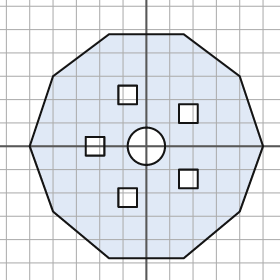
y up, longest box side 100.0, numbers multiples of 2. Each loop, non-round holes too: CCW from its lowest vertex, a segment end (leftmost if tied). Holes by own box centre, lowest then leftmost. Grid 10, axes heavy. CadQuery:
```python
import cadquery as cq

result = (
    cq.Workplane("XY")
    .moveTo(-16.0, -48.0)
    .lineTo(16.0, -48.0)
    .lineTo(40.0, -28.0)
    .lineTo(50.0, 0.0)
    .lineTo(40.0, 30.0)
    .lineTo(16.0, 48.0)
    .lineTo(-16.0, 48.0)
    .lineTo(-40.0, 30.0)
    .lineTo(-50.0, 0.0)
    .lineTo(-40.0, -28.0)
    .close()
    .moveTo(-12.0, -26.0)
    .lineTo(-4.0, -26.0)
    .lineTo(-4.0, -18.0)
    .lineTo(-12.0, -18.0)
    .close()
    .moveTo(14.0, -18.0)
    .lineTo(22.0, -18.0)
    .lineTo(22.0, -10.0)
    .lineTo(14.0, -10.0)
    .close()
    .moveTo(-26.0, -4.0)
    .lineTo(-18.0, -4.0)
    .lineTo(-18.0, 4.0)
    .lineTo(-26.0, 4.0)
    .close()
    .moveTo(0.0, 0.0)
    .circle(8.0)
    .moveTo(14.0, 10.0)
    .lineTo(22.0, 10.0)
    .lineTo(22.0, 18.0)
    .lineTo(14.0, 18.0)
    .close()
    .moveTo(-12.0, 18.0)
    .lineTo(-4.0, 18.0)
    .lineTo(-4.0, 26.0)
    .lineTo(-12.0, 26.0)
    .close()
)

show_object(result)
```